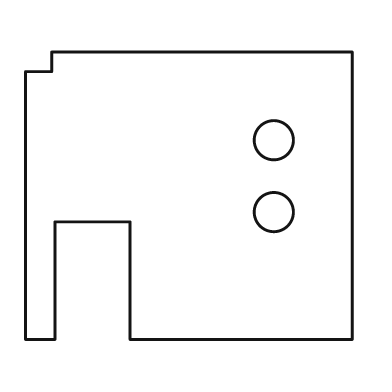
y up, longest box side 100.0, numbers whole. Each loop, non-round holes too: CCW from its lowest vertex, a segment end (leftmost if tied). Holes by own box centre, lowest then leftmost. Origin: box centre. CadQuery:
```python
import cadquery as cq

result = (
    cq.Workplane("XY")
    .moveTo(-50.0, -44.0)
    .lineTo(-41.0, -44.0)
    .lineTo(-41.0, -8.0)
    .lineTo(-18.0, -8.0)
    .lineTo(-18.0, -44.0)
    .lineTo(50.0, -44.0)
    .lineTo(50.0, 44.0)
    .lineTo(-42.0, 44.0)
    .lineTo(-42.0, 38.0)
    .lineTo(-50.0, 38.0)
    .close()
    .moveTo(26.0, -5.0)
    .circle(6.0)
    .moveTo(26.0, 17.0)
    .circle(6.0)
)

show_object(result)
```